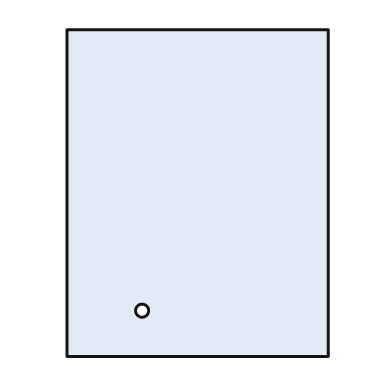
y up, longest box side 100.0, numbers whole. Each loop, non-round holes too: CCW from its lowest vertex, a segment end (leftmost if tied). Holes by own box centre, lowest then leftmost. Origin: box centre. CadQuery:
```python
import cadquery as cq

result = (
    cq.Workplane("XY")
    .moveTo(-40.0, -50.0)
    .lineTo(40.0, -50.0)
    .lineTo(40.0, 50.0)
    .lineTo(-40.0, 50.0)
    .close()
    .moveTo(-17.0, -36.0)
    .circle(2.0)
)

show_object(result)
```